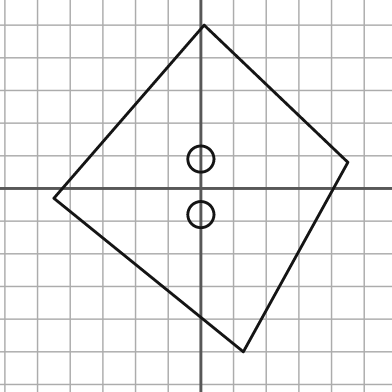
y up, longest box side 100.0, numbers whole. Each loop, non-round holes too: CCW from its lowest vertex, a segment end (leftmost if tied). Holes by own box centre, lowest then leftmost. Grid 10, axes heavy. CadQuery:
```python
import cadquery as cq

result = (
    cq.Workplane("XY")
    .moveTo(13.0, -50.0)
    .lineTo(45.0, 8.0)
    .lineTo(1.0, 50.0)
    .lineTo(-45.0, -3.0)
    .close()
    .moveTo(0.0, -8.0)
    .circle(4.0)
    .moveTo(0.0, 9.0)
    .circle(4.0)
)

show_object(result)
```